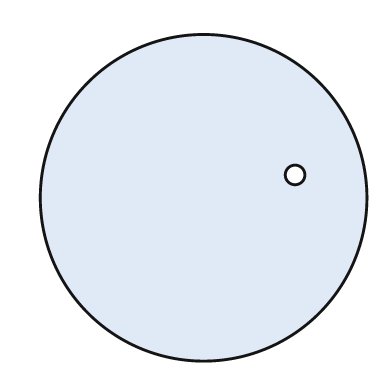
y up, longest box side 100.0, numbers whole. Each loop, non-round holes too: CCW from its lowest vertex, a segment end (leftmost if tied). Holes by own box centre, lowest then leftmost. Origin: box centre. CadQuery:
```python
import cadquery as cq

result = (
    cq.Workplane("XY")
    .moveTo(0.0, 0.0)
    .circle(50.0)
    .moveTo(28.0, 7.0)
    .circle(3.0)
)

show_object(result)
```